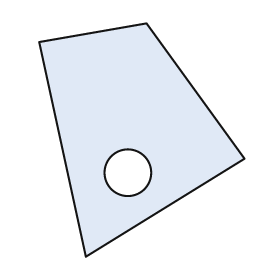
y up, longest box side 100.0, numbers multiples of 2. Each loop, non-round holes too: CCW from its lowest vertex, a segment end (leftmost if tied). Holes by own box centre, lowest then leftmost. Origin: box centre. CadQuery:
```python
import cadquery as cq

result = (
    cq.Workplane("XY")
    .moveTo(-24.0, -50.0)
    .lineTo(44.0, -8.0)
    .lineTo(2.0, 50.0)
    .lineTo(-44.0, 42.0)
    .close()
    .moveTo(-6.0, -14.0)
    .circle(10.0)
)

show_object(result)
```